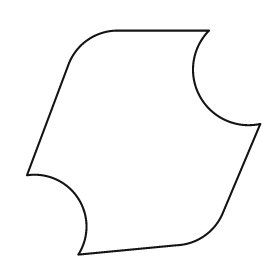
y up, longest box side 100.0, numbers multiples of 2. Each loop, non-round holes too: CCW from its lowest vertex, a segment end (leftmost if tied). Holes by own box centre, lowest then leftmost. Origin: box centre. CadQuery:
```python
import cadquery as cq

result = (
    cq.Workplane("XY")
    .moveTo(-28.0, -48.0)
    .lineTo(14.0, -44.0)
    .threePointArc((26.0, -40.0), (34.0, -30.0))
    .lineTo(50.0, 8.0)
    .threePointArc((24.0, 20.0), (28.0, 48.0))
    .lineTo(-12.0, 48.0)
    .threePointArc((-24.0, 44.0), (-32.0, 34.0))
    .lineTo(-50.0, -14.0)
    .threePointArc((-28.0, -24.0), (-28.0, -48.0))
    .close()
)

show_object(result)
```